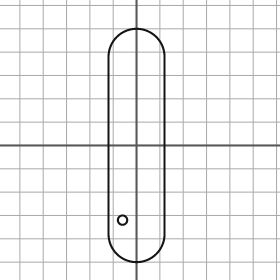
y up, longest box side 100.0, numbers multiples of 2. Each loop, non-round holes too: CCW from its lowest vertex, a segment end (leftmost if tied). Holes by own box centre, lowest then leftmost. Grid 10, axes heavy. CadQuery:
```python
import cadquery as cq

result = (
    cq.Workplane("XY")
    .moveTo(-12.0, -38.0)
    .threePointArc((0.0, -50.0), (12.0, -38.0))
    .lineTo(12.0, 38.0)
    .threePointArc((0.0, 50.0), (-12.0, 38.0))
    .close()
    .moveTo(-6.0, -32.0)
    .circle(2.0)
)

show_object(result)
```